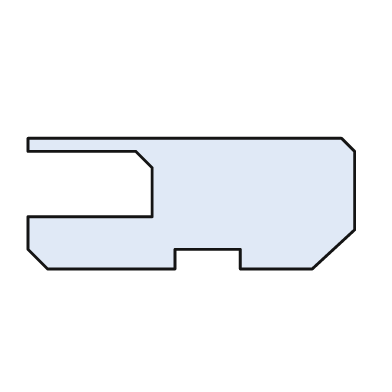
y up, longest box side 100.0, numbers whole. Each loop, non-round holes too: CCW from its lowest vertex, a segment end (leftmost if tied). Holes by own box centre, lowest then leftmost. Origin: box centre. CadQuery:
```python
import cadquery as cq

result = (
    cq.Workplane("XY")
    .moveTo(-44.0, -20.0)
    .lineTo(-5.0, -20.0)
    .lineTo(-5.0, -14.0)
    .lineTo(15.0, -14.0)
    .lineTo(15.0, -20.0)
    .lineTo(37.0, -20.0)
    .lineTo(50.0, -8.0)
    .lineTo(50.0, 16.0)
    .lineTo(46.0, 20.0)
    .lineTo(-50.0, 20.0)
    .lineTo(-50.0, 16.0)
    .lineTo(-17.0, 16.0)
    .lineTo(-12.0, 11.0)
    .lineTo(-12.0, -4.0)
    .lineTo(-50.0, -4.0)
    .lineTo(-50.0, -14.0)
    .close()
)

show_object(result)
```